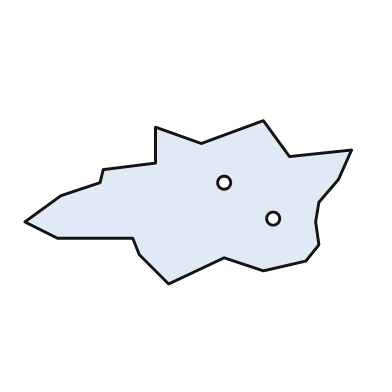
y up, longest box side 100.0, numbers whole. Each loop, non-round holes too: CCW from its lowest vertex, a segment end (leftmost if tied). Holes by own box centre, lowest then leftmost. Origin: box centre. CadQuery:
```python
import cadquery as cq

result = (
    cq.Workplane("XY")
    .moveTo(-6.0, -25.0)
    .lineTo(11.0, -17.0)
    .lineTo(23.0, -21.0)
    .lineTo(36.0, -18.0)
    .lineTo(40.0, -13.0)
    .lineTo(39.0, -6.0)
    .lineTo(40.0, 0.0)
    .lineTo(46.0, 7.0)
    .lineTo(50.0, 16.0)
    .lineTo(31.0, 14.0)
    .lineTo(23.0, 25.0)
    .lineTo(4.0, 18.0)
    .lineTo(-10.0, 23.0)
    .lineTo(-10.0, 12.0)
    .lineTo(-26.0, 10.0)
    .lineTo(-27.0, 6.0)
    .lineTo(-39.0, 2.0)
    .lineTo(-50.0, -6.0)
    .lineTo(-40.0, -11.0)
    .lineTo(-17.0, -11.0)
    .lineTo(-15.0, -16.0)
    .close()
    .moveTo(26.0, -5.0)
    .circle(2.0)
    .moveTo(11.0, 6.0)
    .circle(2.0)
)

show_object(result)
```